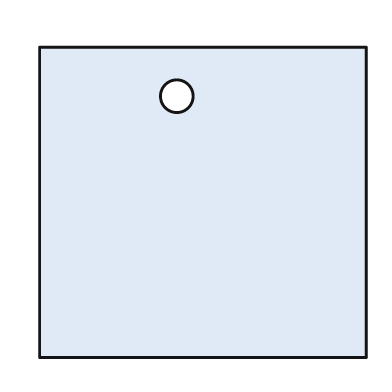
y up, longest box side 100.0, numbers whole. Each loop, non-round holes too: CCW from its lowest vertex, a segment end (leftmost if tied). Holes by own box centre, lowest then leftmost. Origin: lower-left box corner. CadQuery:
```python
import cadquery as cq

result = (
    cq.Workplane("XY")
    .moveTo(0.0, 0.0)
    .lineTo(100.0, 0.0)
    .lineTo(100.0, 95.0)
    .lineTo(0.0, 95.0)
    .close()
    .moveTo(42.0, 80.0)
    .circle(5.0)
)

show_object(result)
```